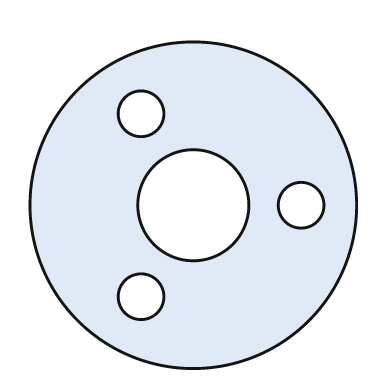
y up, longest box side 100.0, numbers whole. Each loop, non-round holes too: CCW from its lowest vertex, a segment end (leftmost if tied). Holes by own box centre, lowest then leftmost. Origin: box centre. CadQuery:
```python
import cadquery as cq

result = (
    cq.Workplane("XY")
    .moveTo(0.0, 0.0)
    .circle(50.0)
    .moveTo(-16.0, -28.0)
    .circle(7.0)
    .moveTo(0.0, 0.0)
    .circle(17.0)
    .moveTo(33.0, 0.0)
    .circle(7.0)
    .moveTo(-16.0, 28.0)
    .circle(7.0)
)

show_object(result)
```